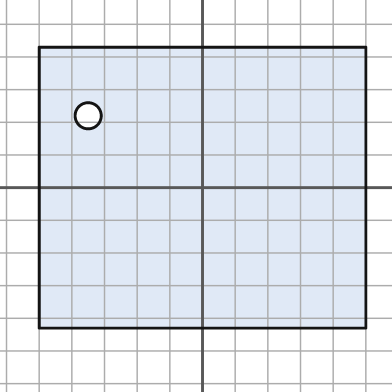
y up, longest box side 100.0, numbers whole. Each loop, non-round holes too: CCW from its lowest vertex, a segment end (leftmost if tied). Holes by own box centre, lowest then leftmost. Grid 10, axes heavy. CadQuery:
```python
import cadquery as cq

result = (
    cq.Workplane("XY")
    .moveTo(-50.0, -43.0)
    .lineTo(50.0, -43.0)
    .lineTo(50.0, 43.0)
    .lineTo(-50.0, 43.0)
    .close()
    .moveTo(-35.0, 22.0)
    .circle(4.0)
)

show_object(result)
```